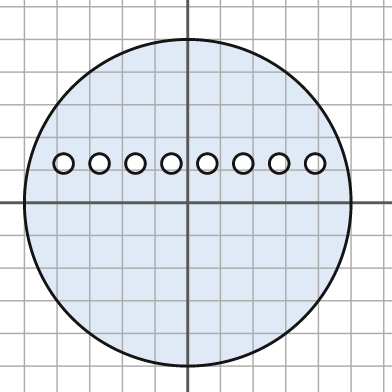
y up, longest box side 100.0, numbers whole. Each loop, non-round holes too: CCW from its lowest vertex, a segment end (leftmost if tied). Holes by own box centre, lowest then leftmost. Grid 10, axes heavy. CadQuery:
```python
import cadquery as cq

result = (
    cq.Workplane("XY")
    .moveTo(0.0, 0.0)
    .circle(50.0)
    .moveTo(-38.0, 12.0)
    .circle(3.0)
    .moveTo(-27.0, 12.0)
    .circle(3.0)
    .moveTo(-16.0, 12.0)
    .circle(3.0)
    .moveTo(-5.0, 12.0)
    .circle(3.0)
    .moveTo(6.0, 12.0)
    .circle(3.0)
    .moveTo(17.0, 12.0)
    .circle(3.0)
    .moveTo(28.0, 12.0)
    .circle(3.0)
    .moveTo(39.0, 12.0)
    .circle(3.0)
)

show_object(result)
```